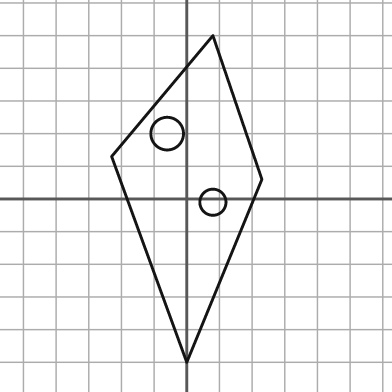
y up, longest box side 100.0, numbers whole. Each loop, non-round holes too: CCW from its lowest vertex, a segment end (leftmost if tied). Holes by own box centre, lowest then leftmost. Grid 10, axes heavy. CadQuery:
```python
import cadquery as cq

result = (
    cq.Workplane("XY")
    .moveTo(0.0, -50.0)
    .lineTo(23.0, 6.0)
    .lineTo(8.0, 50.0)
    .lineTo(-23.0, 13.0)
    .close()
    .moveTo(8.0, -1.0)
    .circle(4.0)
    .moveTo(-6.0, 20.0)
    .circle(5.0)
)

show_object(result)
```